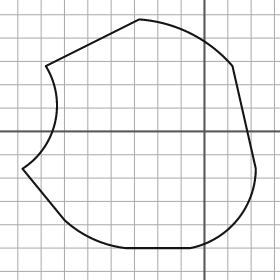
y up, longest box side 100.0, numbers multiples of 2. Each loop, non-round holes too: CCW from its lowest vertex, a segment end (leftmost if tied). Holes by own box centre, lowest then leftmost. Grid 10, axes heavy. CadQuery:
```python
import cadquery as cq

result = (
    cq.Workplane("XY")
    .moveTo(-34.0, -50.0)
    .lineTo(-6.0, -50.0)
    .threePointArc((14.0, -38.0), (22.0, -16.0))
    .lineTo(12.0, 28.0)
    .threePointArc((-6.0, 42.0), (-28.0, 48.0))
    .lineTo(-68.0, 28.0)
    .threePointArc((-64.0, 4.0), (-78.0, -16.0))
    .lineTo(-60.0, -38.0)
    .threePointArc((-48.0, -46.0), (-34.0, -50.0))
    .close()
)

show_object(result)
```